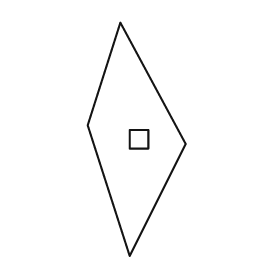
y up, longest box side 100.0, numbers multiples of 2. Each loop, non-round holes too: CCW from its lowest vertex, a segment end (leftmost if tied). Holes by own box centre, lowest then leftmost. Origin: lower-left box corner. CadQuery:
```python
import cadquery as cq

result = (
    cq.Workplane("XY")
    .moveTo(18.0, 0.0)
    .lineTo(42.0, 48.0)
    .lineTo(14.0, 100.0)
    .lineTo(0.0, 56.0)
    .close()
    .moveTo(18.0, 46.0)
    .lineTo(26.0, 46.0)
    .lineTo(26.0, 54.0)
    .lineTo(18.0, 54.0)
    .close()
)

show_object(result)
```